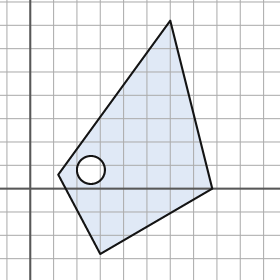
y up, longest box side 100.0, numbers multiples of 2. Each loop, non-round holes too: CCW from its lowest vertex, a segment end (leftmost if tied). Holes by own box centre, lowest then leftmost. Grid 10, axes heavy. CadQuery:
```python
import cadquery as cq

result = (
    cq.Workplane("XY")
    .moveTo(30.0, -28.0)
    .lineTo(78.0, 0.0)
    .lineTo(60.0, 72.0)
    .lineTo(12.0, 6.0)
    .close()
    .moveTo(26.0, 8.0)
    .circle(6.0)
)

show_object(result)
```